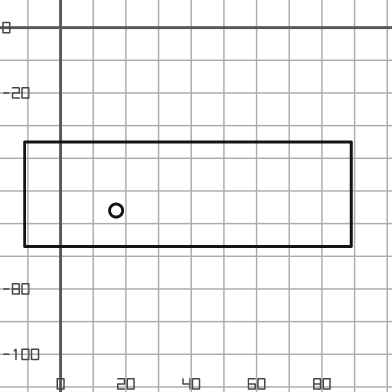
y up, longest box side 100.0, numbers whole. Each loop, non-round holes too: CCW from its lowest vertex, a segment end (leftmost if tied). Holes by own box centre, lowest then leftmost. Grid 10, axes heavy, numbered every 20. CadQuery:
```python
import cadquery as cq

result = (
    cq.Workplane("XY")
    .moveTo(-11.0, -67.0)
    .lineTo(89.0, -67.0)
    .lineTo(89.0, -35.0)
    .lineTo(-11.0, -35.0)
    .close()
    .moveTo(17.0, -56.0)
    .circle(2.0)
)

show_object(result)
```